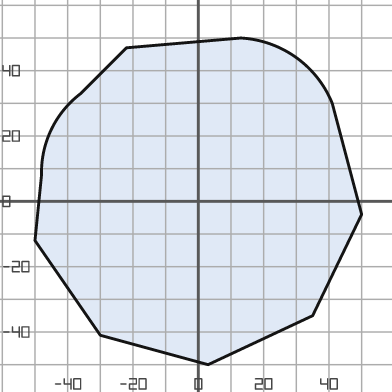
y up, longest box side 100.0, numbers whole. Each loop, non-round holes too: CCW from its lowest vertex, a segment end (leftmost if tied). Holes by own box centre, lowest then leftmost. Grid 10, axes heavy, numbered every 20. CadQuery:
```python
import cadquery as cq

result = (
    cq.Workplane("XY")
    .moveTo(3.0, -50.0)
    .lineTo(35.0, -35.0)
    .lineTo(50.0, -4.0)
    .lineTo(41.0, 30.0)
    .threePointArc((30.0, 44.0), (13.0, 50.0))
    .lineTo(-22.0, 47.0)
    .lineTo(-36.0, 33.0)
    .threePointArc((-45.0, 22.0), (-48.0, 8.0))
    .lineTo(-50.0, -12.0)
    .lineTo(-30.0, -41.0)
    .close()
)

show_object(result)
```